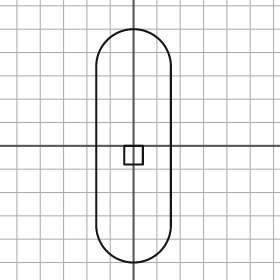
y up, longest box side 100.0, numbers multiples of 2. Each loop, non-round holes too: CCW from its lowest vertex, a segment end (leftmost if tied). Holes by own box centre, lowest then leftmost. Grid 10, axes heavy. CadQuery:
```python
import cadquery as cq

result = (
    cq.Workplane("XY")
    .moveTo(-16.0, -34.0)
    .threePointArc((0.0, -50.0), (16.0, -34.0))
    .lineTo(16.0, 34.0)
    .threePointArc((0.0, 50.0), (-16.0, 34.0))
    .close()
    .moveTo(-4.0, -8.0)
    .lineTo(4.0, -8.0)
    .lineTo(4.0, 0.0)
    .lineTo(-4.0, 0.0)
    .close()
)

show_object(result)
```